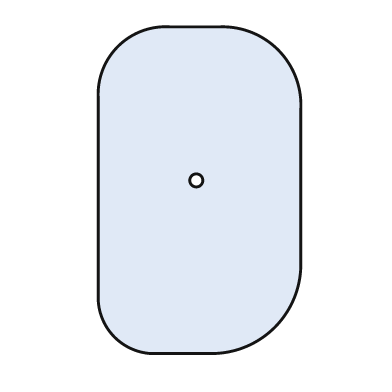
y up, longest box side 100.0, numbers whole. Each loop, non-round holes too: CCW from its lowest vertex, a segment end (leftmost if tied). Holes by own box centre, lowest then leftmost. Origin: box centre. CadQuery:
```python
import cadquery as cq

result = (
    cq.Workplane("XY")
    .moveTo(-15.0, -50.0)
    .lineTo(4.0, -50.0)
    .threePointArc((23.0, -42.0), (31.0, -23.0))
    .lineTo(31.0, 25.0)
    .threePointArc((24.0, 43.0), (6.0, 50.0))
    .lineTo(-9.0, 50.0)
    .threePointArc((-25.0, 44.0), (-31.0, 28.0))
    .lineTo(-31.0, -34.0)
    .threePointArc((-26.0, -45.0), (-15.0, -50.0))
    .close()
    .moveTo(-1.0, 3.0)
    .circle(2.0)
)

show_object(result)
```